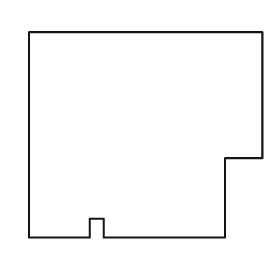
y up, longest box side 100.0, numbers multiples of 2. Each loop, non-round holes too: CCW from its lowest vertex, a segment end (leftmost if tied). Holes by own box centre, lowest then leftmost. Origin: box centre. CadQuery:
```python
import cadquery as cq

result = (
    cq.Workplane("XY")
    .moveTo(-50.0, -44.0)
    .lineTo(-24.0, -44.0)
    .lineTo(-24.0, -36.0)
    .lineTo(-18.0, -36.0)
    .lineTo(-18.0, -44.0)
    .lineTo(34.0, -44.0)
    .lineTo(34.0, -10.0)
    .lineTo(50.0, -10.0)
    .lineTo(50.0, 44.0)
    .lineTo(-50.0, 44.0)
    .close()
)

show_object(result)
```